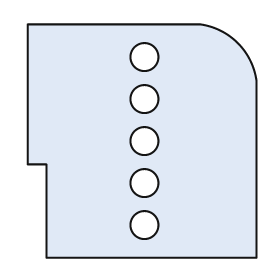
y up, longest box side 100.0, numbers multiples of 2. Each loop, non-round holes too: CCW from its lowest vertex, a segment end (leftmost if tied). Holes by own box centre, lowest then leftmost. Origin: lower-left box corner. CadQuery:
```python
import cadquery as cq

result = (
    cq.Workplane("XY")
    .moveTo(8.0, 0.0)
    .lineTo(98.0, 0.0)
    .lineTo(98.0, 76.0)
    .threePointArc((90.0, 92.0), (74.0, 100.0))
    .lineTo(0.0, 100.0)
    .lineTo(0.0, 40.0)
    .lineTo(8.0, 40.0)
    .close()
    .moveTo(50.0, 14.0)
    .circle(6.0)
    .moveTo(50.0, 32.0)
    .circle(6.0)
    .moveTo(50.0, 50.0)
    .circle(6.0)
    .moveTo(50.0, 68.0)
    .circle(6.0)
    .moveTo(50.0, 86.0)
    .circle(6.0)
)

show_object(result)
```